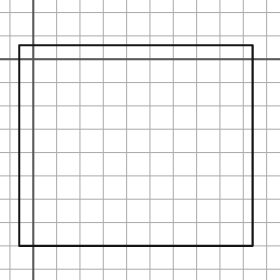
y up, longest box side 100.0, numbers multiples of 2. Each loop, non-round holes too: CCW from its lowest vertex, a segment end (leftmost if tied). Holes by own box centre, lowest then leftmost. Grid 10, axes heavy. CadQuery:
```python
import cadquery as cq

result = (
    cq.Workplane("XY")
    .moveTo(-6.0, -80.0)
    .lineTo(94.0, -80.0)
    .lineTo(94.0, 6.0)
    .lineTo(-6.0, 6.0)
    .close()
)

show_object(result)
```